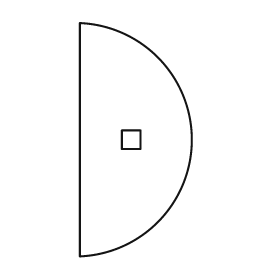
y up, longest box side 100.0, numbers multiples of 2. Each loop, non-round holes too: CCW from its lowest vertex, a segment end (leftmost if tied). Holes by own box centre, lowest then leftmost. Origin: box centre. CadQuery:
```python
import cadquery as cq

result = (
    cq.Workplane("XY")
    .moveTo(-24.0, -50.0)
    .threePointArc((24.0, 0.0), (-24.0, 50.0))
    .close()
    .moveTo(-6.0, -4.0)
    .lineTo(2.0, -4.0)
    .lineTo(2.0, 4.0)
    .lineTo(-6.0, 4.0)
    .close()
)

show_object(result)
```